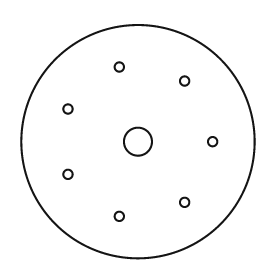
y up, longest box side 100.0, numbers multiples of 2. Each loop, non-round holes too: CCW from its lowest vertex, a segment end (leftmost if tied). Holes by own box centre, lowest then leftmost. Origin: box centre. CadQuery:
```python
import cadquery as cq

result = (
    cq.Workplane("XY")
    .moveTo(0.0, 0.0)
    .circle(50.0)
    .moveTo(-8.0, -32.0)
    .circle(2.0)
    .moveTo(20.0, -26.0)
    .circle(2.0)
    .moveTo(-30.0, -14.0)
    .circle(2.0)
    .moveTo(0.0, 0.0)
    .circle(6.0)
    .moveTo(32.0, 0.0)
    .circle(2.0)
    .moveTo(-30.0, 14.0)
    .circle(2.0)
    .moveTo(20.0, 26.0)
    .circle(2.0)
    .moveTo(-8.0, 32.0)
    .circle(2.0)
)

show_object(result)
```